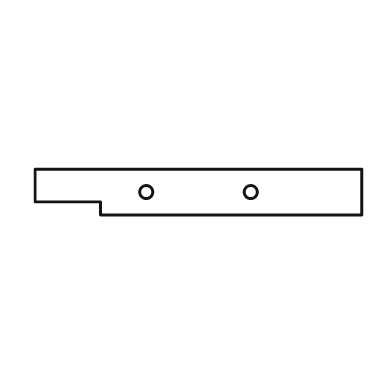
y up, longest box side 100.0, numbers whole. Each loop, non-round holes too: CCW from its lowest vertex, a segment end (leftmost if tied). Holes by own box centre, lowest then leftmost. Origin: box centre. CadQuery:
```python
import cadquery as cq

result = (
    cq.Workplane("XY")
    .moveTo(-30.0, -7.0)
    .lineTo(50.0, -7.0)
    .lineTo(50.0, 7.0)
    .lineTo(-50.0, 7.0)
    .lineTo(-50.0, -3.0)
    .lineTo(-30.0, -3.0)
    .close()
    .moveTo(-16.0, 0.0)
    .circle(2.0)
    .moveTo(16.0, 0.0)
    .circle(2.0)
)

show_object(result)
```